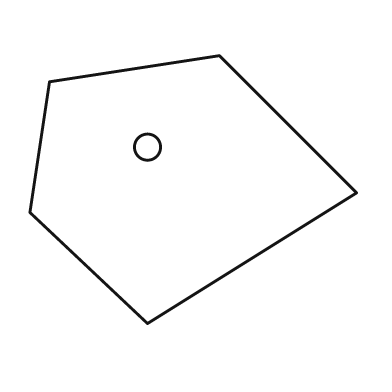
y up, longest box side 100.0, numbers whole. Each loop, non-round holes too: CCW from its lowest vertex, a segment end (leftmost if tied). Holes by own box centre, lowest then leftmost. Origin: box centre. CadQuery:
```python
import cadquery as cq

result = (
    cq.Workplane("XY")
    .moveTo(-14.0, -41.0)
    .lineTo(50.0, -1.0)
    .lineTo(8.0, 41.0)
    .lineTo(-44.0, 33.0)
    .lineTo(-50.0, -7.0)
    .close()
    .moveTo(-14.0, 13.0)
    .circle(4.0)
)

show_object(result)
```